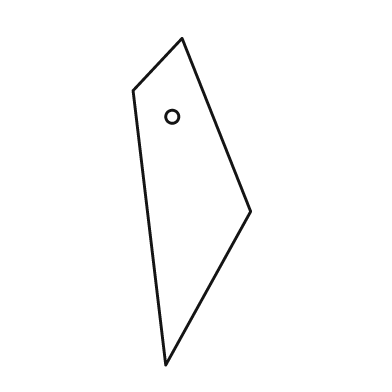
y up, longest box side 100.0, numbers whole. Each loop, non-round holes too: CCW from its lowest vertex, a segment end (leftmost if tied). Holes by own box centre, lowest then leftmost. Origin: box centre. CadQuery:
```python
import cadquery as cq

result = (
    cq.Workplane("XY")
    .moveTo(-8.0, -50.0)
    .lineTo(18.0, -3.0)
    .lineTo(-3.0, 50.0)
    .lineTo(-18.0, 34.0)
    .close()
    .moveTo(-6.0, 26.0)
    .circle(2.0)
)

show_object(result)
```